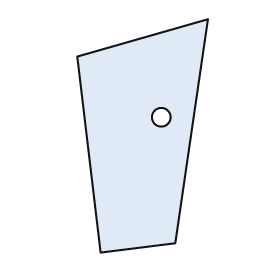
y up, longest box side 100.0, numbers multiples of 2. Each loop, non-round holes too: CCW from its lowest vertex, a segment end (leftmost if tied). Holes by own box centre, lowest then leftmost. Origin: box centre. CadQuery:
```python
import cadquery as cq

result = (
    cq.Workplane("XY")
    .moveTo(-18.0, -50.0)
    .lineTo(14.0, -46.0)
    .lineTo(28.0, 50.0)
    .lineTo(-28.0, 34.0)
    .close()
    .moveTo(8.0, 8.0)
    .circle(4.0)
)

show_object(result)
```